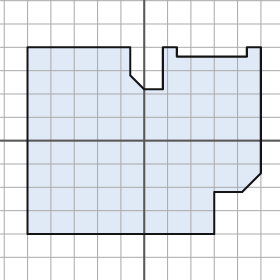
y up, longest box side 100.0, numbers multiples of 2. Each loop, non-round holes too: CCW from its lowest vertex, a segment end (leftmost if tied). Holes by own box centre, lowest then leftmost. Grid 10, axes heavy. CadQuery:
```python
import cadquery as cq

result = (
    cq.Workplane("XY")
    .moveTo(-50.0, -40.0)
    .lineTo(30.0, -40.0)
    .lineTo(30.0, -22.0)
    .lineTo(42.0, -22.0)
    .lineTo(50.0, -14.0)
    .lineTo(50.0, 40.0)
    .lineTo(44.0, 40.0)
    .lineTo(44.0, 36.0)
    .lineTo(14.0, 36.0)
    .lineTo(14.0, 40.0)
    .lineTo(8.0, 40.0)
    .lineTo(8.0, 22.0)
    .lineTo(0.0, 22.0)
    .lineTo(-6.0, 28.0)
    .lineTo(-6.0, 40.0)
    .lineTo(-50.0, 40.0)
    .close()
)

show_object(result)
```